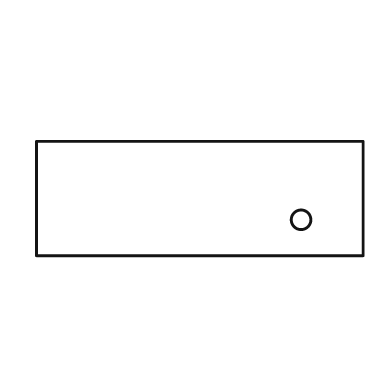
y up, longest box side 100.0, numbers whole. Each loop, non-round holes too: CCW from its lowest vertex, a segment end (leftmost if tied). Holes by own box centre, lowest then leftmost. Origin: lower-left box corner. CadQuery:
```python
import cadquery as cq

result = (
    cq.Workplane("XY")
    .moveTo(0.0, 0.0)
    .lineTo(100.0, 0.0)
    .lineTo(100.0, 35.0)
    .lineTo(0.0, 35.0)
    .close()
    .moveTo(81.0, 11.0)
    .circle(3.0)
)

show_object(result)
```